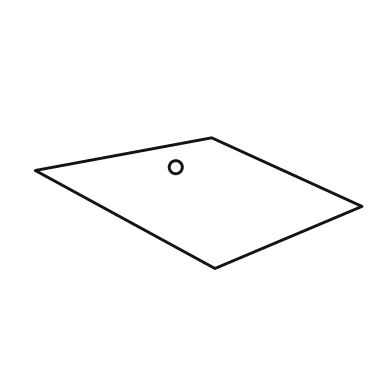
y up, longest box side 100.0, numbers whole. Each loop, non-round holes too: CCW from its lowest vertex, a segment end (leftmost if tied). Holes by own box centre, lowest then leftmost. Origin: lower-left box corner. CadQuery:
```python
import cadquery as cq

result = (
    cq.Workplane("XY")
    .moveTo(55.0, 0.0)
    .lineTo(100.0, 19.0)
    .lineTo(54.0, 40.0)
    .lineTo(0.0, 30.0)
    .close()
    .moveTo(43.0, 31.0)
    .circle(2.0)
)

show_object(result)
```